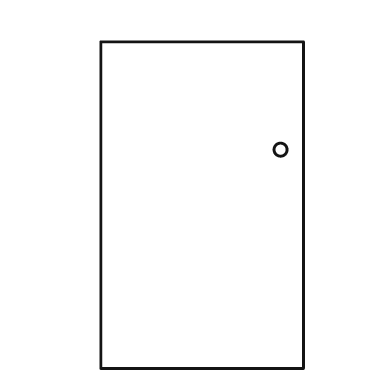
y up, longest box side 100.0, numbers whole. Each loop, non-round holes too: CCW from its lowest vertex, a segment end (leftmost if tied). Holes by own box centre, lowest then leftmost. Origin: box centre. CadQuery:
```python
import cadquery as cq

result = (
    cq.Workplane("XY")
    .moveTo(-31.0, -50.0)
    .lineTo(31.0, -50.0)
    .lineTo(31.0, 50.0)
    .lineTo(-31.0, 50.0)
    .close()
    .moveTo(24.0, 17.0)
    .circle(2.0)
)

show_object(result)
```